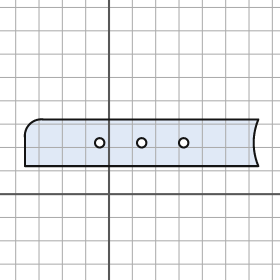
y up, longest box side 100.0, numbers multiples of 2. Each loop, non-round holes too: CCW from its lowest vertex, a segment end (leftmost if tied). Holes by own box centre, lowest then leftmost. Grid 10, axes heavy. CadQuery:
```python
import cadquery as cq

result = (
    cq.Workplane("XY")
    .moveTo(-36.0, 12.0)
    .lineTo(64.0, 12.0)
    .threePointArc((62.0, 22.0), (64.0, 32.0))
    .lineTo(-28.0, 32.0)
    .threePointArc((-34.0, 30.0), (-36.0, 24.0))
    .close()
    .moveTo(-4.0, 22.0)
    .circle(2.0)
    .moveTo(14.0, 22.0)
    .circle(2.0)
    .moveTo(32.0, 22.0)
    .circle(2.0)
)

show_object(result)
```